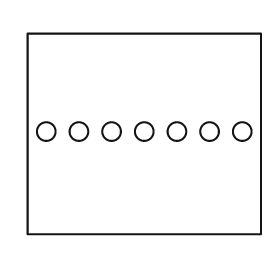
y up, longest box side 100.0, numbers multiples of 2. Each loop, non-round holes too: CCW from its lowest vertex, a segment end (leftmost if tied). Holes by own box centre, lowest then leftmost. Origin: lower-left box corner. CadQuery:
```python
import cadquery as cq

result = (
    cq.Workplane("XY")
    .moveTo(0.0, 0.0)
    .lineTo(100.0, 0.0)
    .lineTo(100.0, 86.0)
    .lineTo(0.0, 86.0)
    .close()
    .moveTo(8.0, 44.0)
    .circle(4.0)
    .moveTo(22.0, 44.0)
    .circle(4.0)
    .moveTo(36.0, 44.0)
    .circle(4.0)
    .moveTo(50.0, 44.0)
    .circle(4.0)
    .moveTo(64.0, 44.0)
    .circle(4.0)
    .moveTo(78.0, 44.0)
    .circle(4.0)
    .moveTo(92.0, 44.0)
    .circle(4.0)
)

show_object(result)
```